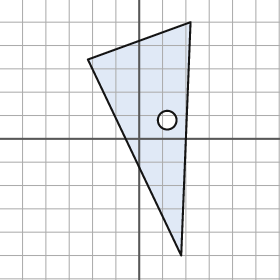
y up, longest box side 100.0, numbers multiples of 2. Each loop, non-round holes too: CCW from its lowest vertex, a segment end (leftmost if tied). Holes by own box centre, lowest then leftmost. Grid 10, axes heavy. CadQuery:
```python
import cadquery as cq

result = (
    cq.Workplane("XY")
    .moveTo(18.0, -50.0)
    .lineTo(22.0, 50.0)
    .lineTo(-22.0, 34.0)
    .close()
    .moveTo(12.0, 8.0)
    .circle(4.0)
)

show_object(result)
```